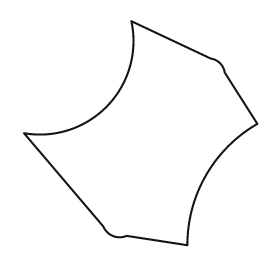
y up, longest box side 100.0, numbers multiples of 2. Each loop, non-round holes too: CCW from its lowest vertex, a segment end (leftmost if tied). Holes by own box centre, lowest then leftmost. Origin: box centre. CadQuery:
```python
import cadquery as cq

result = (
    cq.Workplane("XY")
    .moveTo(20.0, -48.0)
    .threePointArc((28.0, -18.0), (50.0, 4.0))
    .lineTo(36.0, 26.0)
    .threePointArc((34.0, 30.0), (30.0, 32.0))
    .lineTo(-4.0, 48.0)
    .threePointArc((-14.0, 12.0), (-50.0, 0.0))
    .lineTo(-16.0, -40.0)
    .threePointArc((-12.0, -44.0), (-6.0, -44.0))
    .close()
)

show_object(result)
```